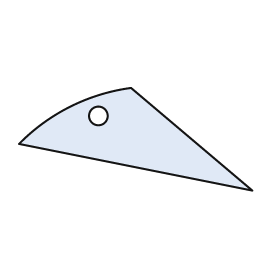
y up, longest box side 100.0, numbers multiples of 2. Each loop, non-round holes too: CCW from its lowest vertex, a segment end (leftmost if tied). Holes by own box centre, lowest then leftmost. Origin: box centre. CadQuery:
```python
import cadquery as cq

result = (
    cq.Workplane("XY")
    .moveTo(50.0, -22.0)
    .lineTo(-2.0, 22.0)
    .threePointArc((-28.0, 14.0), (-50.0, -2.0))
    .close()
    .moveTo(-16.0, 10.0)
    .circle(4.0)
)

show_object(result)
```